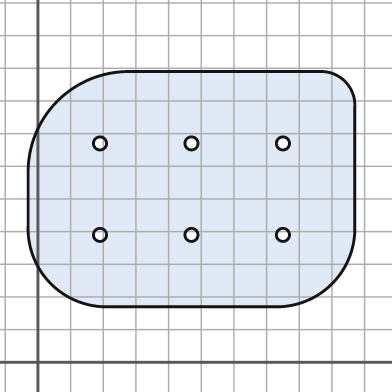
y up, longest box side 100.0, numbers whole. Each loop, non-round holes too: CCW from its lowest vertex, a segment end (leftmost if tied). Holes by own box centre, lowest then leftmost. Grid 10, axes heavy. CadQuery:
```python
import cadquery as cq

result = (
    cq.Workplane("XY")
    .moveTo(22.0, 17.0)
    .lineTo(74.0, 17.0)
    .threePointArc((90.0, 24.0), (97.0, 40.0))
    .lineTo(97.0, 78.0)
    .threePointArc((94.0, 86.0), (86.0, 89.0))
    .lineTo(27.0, 89.0)
    .threePointArc((6.0, 80.0), (-3.0, 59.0))
    .lineTo(-3.0, 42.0)
    .threePointArc((4.0, 24.0), (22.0, 17.0))
    .close()
    .moveTo(19.0, 39.0)
    .circle(2.0)
    .moveTo(47.0, 39.0)
    .circle(2.0)
    .moveTo(75.0, 39.0)
    .circle(2.0)
    .moveTo(19.0, 67.0)
    .circle(2.0)
    .moveTo(47.0, 67.0)
    .circle(2.0)
    .moveTo(75.0, 67.0)
    .circle(2.0)
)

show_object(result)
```